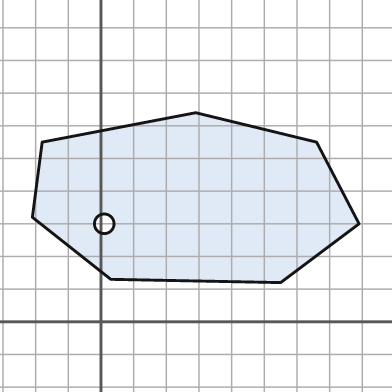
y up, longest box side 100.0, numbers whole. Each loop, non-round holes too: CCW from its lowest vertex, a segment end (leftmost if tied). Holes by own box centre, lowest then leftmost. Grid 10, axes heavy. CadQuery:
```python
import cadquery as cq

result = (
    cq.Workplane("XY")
    .moveTo(55.0, 12.0)
    .lineTo(79.0, 30.0)
    .lineTo(66.0, 55.0)
    .lineTo(29.0, 64.0)
    .lineTo(-18.0, 55.0)
    .lineTo(-21.0, 32.0)
    .lineTo(3.0, 13.0)
    .close()
    .moveTo(1.0, 30.0)
    .circle(3.0)
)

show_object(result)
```